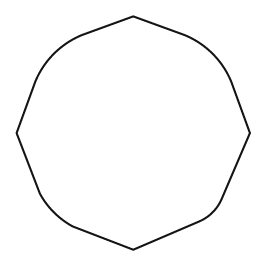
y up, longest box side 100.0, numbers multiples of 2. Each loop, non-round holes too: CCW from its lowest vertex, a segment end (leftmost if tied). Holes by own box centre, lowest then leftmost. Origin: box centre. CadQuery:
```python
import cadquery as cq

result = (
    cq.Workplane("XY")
    .moveTo(0.0, -50.0)
    .lineTo(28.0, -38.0)
    .threePointArc((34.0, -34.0), (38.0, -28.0))
    .lineTo(50.0, 0.0)
    .lineTo(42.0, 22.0)
    .threePointArc((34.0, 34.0), (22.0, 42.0))
    .lineTo(0.0, 50.0)
    .lineTo(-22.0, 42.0)
    .threePointArc((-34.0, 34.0), (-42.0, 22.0))
    .lineTo(-50.0, 0.0)
    .lineTo(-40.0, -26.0)
    .threePointArc((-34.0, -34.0), (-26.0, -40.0))
    .close()
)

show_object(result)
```